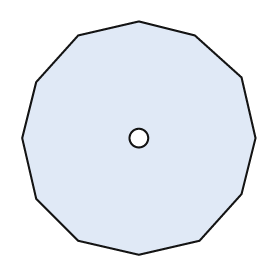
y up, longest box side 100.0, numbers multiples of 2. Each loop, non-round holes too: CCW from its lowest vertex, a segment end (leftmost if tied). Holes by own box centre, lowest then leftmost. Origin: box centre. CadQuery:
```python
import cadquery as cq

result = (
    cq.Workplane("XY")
    .moveTo(0.0, -50.0)
    .lineTo(26.0, -44.0)
    .lineTo(44.0, -24.0)
    .lineTo(50.0, 0.0)
    .lineTo(44.0, 26.0)
    .lineTo(24.0, 44.0)
    .lineTo(0.0, 50.0)
    .lineTo(-26.0, 44.0)
    .lineTo(-44.0, 24.0)
    .lineTo(-50.0, 0.0)
    .lineTo(-44.0, -26.0)
    .lineTo(-26.0, -44.0)
    .close()
    .moveTo(0.0, 0.0)
    .circle(4.0)
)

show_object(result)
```